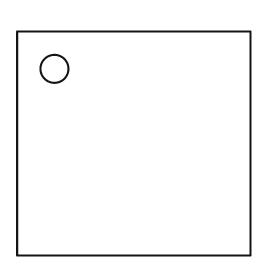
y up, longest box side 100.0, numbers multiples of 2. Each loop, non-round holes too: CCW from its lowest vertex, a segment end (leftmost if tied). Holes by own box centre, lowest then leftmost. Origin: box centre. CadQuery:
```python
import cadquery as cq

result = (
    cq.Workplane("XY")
    .moveTo(-50.0, -48.0)
    .lineTo(50.0, -48.0)
    .lineTo(50.0, 48.0)
    .lineTo(-50.0, 48.0)
    .close()
    .moveTo(-34.0, 32.0)
    .circle(6.0)
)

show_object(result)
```